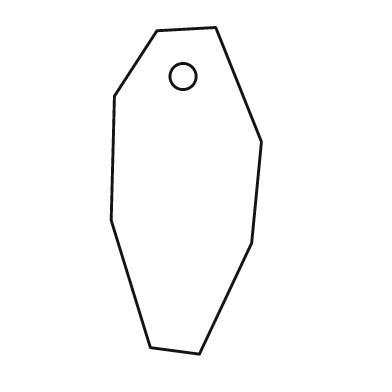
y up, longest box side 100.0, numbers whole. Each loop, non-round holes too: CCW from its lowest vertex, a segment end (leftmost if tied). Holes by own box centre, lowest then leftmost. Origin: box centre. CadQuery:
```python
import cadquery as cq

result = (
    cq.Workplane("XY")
    .moveTo(4.0, -50.0)
    .lineTo(20.0, -16.0)
    .lineTo(23.0, 15.0)
    .lineTo(9.0, 50.0)
    .lineTo(-9.0, 49.0)
    .lineTo(-22.0, 29.0)
    .lineTo(-23.0, -9.0)
    .lineTo(-11.0, -48.0)
    .close()
    .moveTo(-1.0, 35.0)
    .circle(4.0)
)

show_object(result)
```